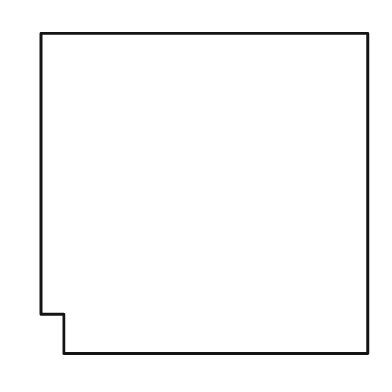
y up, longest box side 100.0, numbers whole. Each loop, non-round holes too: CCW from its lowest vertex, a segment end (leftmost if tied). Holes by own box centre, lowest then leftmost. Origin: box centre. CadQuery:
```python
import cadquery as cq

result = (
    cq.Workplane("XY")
    .moveTo(-43.0, -49.0)
    .lineTo(50.0, -49.0)
    .lineTo(50.0, 49.0)
    .lineTo(-50.0, 49.0)
    .lineTo(-50.0, -37.0)
    .lineTo(-43.0, -37.0)
    .close()
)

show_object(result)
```